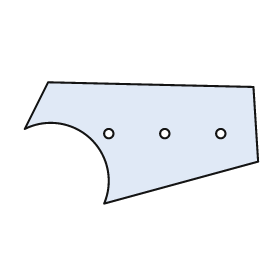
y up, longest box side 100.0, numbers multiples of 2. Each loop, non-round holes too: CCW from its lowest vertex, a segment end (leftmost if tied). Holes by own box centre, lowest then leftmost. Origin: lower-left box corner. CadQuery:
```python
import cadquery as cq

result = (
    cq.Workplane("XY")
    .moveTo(34.0, 0.0)
    .lineTo(100.0, 18.0)
    .lineTo(98.0, 50.0)
    .lineTo(10.0, 52.0)
    .lineTo(0.0, 32.0)
    .threePointArc((28.0, 28.0), (34.0, 0.0))
    .close()
    .moveTo(36.0, 30.0)
    .circle(2.0)
    .moveTo(60.0, 30.0)
    .circle(2.0)
    .moveTo(84.0, 30.0)
    .circle(2.0)
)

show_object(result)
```